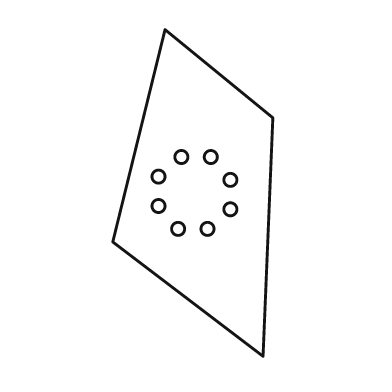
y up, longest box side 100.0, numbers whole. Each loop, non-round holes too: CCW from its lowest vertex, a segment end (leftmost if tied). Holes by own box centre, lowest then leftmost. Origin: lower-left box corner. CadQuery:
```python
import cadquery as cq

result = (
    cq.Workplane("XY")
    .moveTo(46.0, 0.0)
    .lineTo(49.0, 73.0)
    .lineTo(16.0, 100.0)
    .lineTo(0.0, 35.0)
    .close()
    .moveTo(20.0, 39.0)
    .circle(2.0)
    .moveTo(29.0, 39.0)
    .circle(2.0)
    .moveTo(36.0, 45.0)
    .circle(2.0)
    .moveTo(14.0, 46.0)
    .circle(2.0)
    .moveTo(36.0, 54.0)
    .circle(2.0)
    .moveTo(14.0, 55.0)
    .circle(2.0)
    .moveTo(21.0, 61.0)
    .circle(2.0)
    .moveTo(30.0, 61.0)
    .circle(2.0)
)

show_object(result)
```